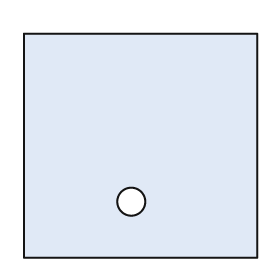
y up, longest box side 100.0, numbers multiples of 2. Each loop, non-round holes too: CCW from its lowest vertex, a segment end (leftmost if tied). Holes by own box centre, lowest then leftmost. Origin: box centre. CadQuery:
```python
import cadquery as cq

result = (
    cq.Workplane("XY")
    .moveTo(-50.0, -48.0)
    .lineTo(50.0, -48.0)
    .lineTo(50.0, 48.0)
    .lineTo(-50.0, 48.0)
    .close()
    .moveTo(-4.0, -24.0)
    .circle(6.0)
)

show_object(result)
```